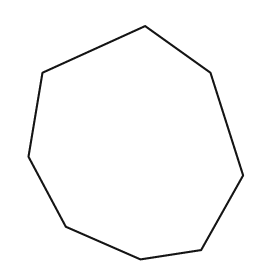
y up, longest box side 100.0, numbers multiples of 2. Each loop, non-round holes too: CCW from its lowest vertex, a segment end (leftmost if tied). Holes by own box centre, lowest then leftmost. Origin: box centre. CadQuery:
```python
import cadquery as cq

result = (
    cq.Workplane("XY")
    .moveTo(2.0, -50.0)
    .lineTo(28.0, -46.0)
    .lineTo(46.0, -14.0)
    .lineTo(32.0, 30.0)
    .lineTo(4.0, 50.0)
    .lineTo(-40.0, 30.0)
    .lineTo(-46.0, -6.0)
    .lineTo(-30.0, -36.0)
    .close()
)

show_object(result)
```